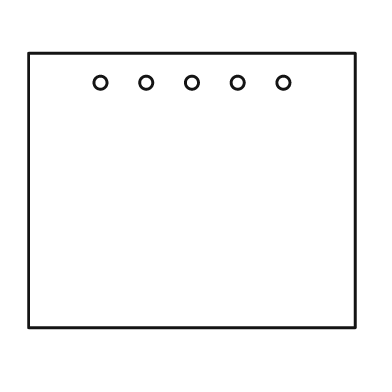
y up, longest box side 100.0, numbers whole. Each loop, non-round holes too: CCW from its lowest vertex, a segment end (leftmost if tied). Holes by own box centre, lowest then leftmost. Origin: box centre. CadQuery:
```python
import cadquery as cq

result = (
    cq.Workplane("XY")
    .moveTo(-50.0, -42.0)
    .lineTo(50.0, -42.0)
    .lineTo(50.0, 42.0)
    .lineTo(-50.0, 42.0)
    .close()
    .moveTo(-28.0, 33.0)
    .circle(2.0)
    .moveTo(-14.0, 33.0)
    .circle(2.0)
    .moveTo(0.0, 33.0)
    .circle(2.0)
    .moveTo(14.0, 33.0)
    .circle(2.0)
    .moveTo(28.0, 33.0)
    .circle(2.0)
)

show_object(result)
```